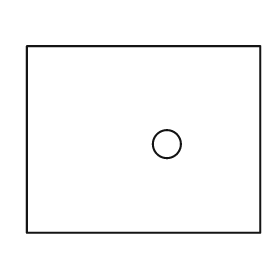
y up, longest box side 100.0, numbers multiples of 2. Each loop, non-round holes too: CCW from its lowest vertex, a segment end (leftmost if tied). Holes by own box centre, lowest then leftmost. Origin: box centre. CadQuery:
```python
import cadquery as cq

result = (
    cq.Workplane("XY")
    .moveTo(-50.0, -40.0)
    .lineTo(50.0, -40.0)
    .lineTo(50.0, 40.0)
    .lineTo(-50.0, 40.0)
    .close()
    .moveTo(10.0, -2.0)
    .circle(6.0)
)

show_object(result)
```